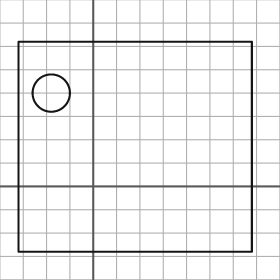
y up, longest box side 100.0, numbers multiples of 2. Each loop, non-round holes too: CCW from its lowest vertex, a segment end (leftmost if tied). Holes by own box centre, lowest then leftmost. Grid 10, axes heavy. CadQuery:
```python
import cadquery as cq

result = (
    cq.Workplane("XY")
    .moveTo(-32.0, -28.0)
    .lineTo(68.0, -28.0)
    .lineTo(68.0, 62.0)
    .lineTo(-32.0, 62.0)
    .close()
    .moveTo(-18.0, 40.0)
    .circle(8.0)
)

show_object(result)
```